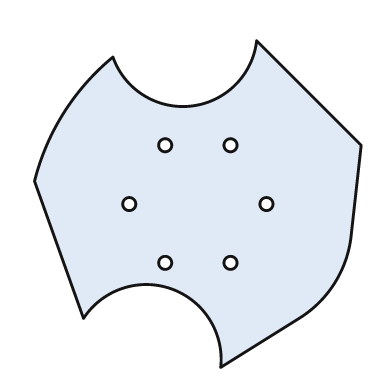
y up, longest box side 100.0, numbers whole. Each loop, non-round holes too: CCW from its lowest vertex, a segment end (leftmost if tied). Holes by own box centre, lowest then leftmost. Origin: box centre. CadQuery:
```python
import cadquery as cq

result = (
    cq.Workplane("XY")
    .moveTo(7.0, -50.0)
    .lineTo(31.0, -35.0)
    .threePointArc((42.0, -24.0), (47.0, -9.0))
    .lineTo(50.0, 18.0)
    .lineTo(18.0, 50.0)
    .threePointArc((-2.0, 30.0), (-26.0, 45.0))
    .threePointArc((-41.0, 28.0), (-50.0, 7.0))
    .lineTo(-35.0, -35.0)
    .threePointArc((-8.0, -26.0), (7.0, -50.0))
    .close()
    .moveTo(-10.0, -18.0)
    .circle(2.0)
    .moveTo(10.0, -18.0)
    .circle(2.0)
    .moveTo(-21.0, 0.0)
    .circle(2.0)
    .moveTo(21.0, 0.0)
    .circle(2.0)
    .moveTo(-10.0, 18.0)
    .circle(2.0)
    .moveTo(10.0, 18.0)
    .circle(2.0)
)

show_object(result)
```